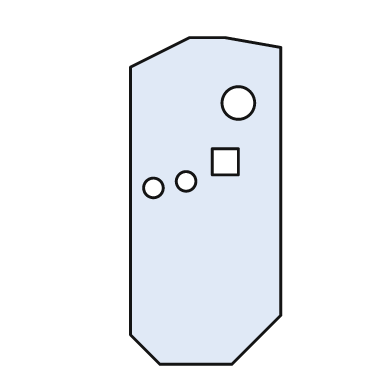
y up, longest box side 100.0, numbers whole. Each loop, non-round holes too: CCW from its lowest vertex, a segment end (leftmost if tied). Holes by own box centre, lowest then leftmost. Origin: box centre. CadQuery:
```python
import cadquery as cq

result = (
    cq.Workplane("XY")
    .moveTo(-14.0, -50.0)
    .lineTo(8.0, -50.0)
    .lineTo(23.0, -35.0)
    .lineTo(23.0, 47.0)
    .lineTo(6.0, 50.0)
    .lineTo(-5.0, 50.0)
    .lineTo(-23.0, 41.0)
    .lineTo(-23.0, -41.0)
    .close()
    .moveTo(-16.0, 4.0)
    .circle(3.0)
    .moveTo(-6.0, 6.0)
    .circle(3.0)
    .moveTo(2.0, 8.0)
    .lineTo(10.0, 8.0)
    .lineTo(10.0, 16.0)
    .lineTo(2.0, 16.0)
    .close()
    .moveTo(10.0, 30.0)
    .circle(5.0)
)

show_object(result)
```